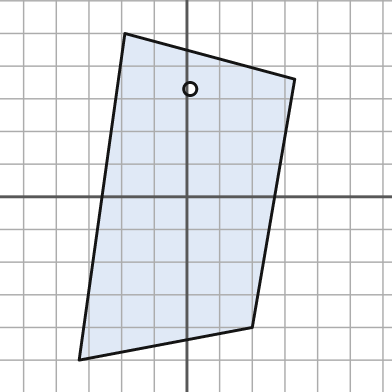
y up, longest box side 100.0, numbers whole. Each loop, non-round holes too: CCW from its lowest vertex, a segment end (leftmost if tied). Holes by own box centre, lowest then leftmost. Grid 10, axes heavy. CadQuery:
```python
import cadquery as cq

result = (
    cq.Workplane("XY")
    .moveTo(-33.0, -50.0)
    .lineTo(20.0, -40.0)
    .lineTo(33.0, 36.0)
    .lineTo(-19.0, 50.0)
    .close()
    .moveTo(1.0, 33.0)
    .circle(2.0)
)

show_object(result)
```